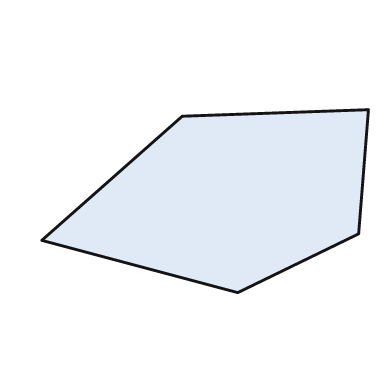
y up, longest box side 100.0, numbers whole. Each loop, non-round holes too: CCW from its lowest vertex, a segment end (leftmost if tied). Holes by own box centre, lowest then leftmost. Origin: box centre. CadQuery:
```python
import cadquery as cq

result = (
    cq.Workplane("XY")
    .moveTo(10.0, -28.0)
    .lineTo(47.0, -10.0)
    .lineTo(50.0, 28.0)
    .lineTo(-7.0, 26.0)
    .lineTo(-50.0, -12.0)
    .close()
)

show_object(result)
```